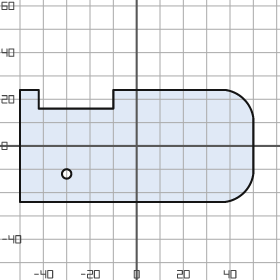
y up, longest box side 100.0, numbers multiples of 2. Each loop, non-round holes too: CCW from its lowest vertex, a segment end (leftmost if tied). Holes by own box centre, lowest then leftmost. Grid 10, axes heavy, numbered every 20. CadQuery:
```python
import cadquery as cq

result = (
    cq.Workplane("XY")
    .moveTo(-50.0, -24.0)
    .lineTo(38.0, -24.0)
    .threePointArc((46.0, -20.0), (50.0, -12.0))
    .lineTo(50.0, 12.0)
    .threePointArc((46.0, 20.0), (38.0, 24.0))
    .lineTo(-10.0, 24.0)
    .lineTo(-10.0, 16.0)
    .lineTo(-42.0, 16.0)
    .lineTo(-42.0, 24.0)
    .lineTo(-50.0, 24.0)
    .close()
    .moveTo(-30.0, -12.0)
    .circle(2.0)
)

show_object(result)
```